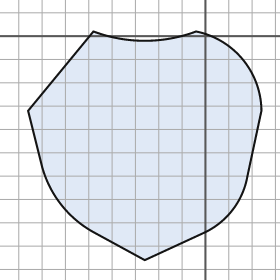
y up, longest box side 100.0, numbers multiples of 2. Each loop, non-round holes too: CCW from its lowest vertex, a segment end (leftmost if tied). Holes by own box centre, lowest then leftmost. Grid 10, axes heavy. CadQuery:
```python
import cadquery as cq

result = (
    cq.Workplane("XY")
    .moveTo(-26.0, -96.0)
    .lineTo(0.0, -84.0)
    .threePointArc((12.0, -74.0), (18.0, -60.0))
    .lineTo(24.0, -32.0)
    .threePointArc((16.0, -10.0), (-4.0, 2.0))
    .threePointArc((-26.0, -2.0), (-48.0, 2.0))
    .lineTo(-76.0, -32.0)
    .lineTo(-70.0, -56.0)
    .threePointArc((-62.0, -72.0), (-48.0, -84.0))
    .close()
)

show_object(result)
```